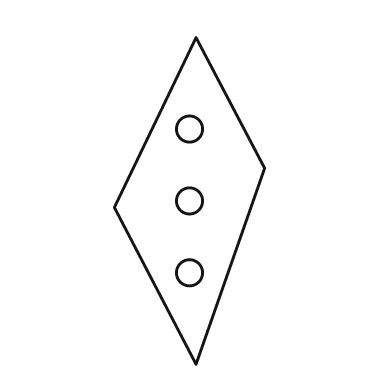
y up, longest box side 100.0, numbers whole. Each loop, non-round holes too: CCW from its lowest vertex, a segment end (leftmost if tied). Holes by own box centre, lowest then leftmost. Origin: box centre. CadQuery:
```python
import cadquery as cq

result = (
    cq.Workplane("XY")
    .moveTo(2.0, -50.0)
    .lineTo(23.0, 10.0)
    .lineTo(2.0, 50.0)
    .lineTo(-23.0, -2.0)
    .close()
    .moveTo(0.0, -22.0)
    .circle(4.0)
    .moveTo(0.0, 0.0)
    .circle(4.0)
    .moveTo(0.0, 22.0)
    .circle(4.0)
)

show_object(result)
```